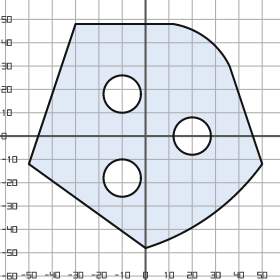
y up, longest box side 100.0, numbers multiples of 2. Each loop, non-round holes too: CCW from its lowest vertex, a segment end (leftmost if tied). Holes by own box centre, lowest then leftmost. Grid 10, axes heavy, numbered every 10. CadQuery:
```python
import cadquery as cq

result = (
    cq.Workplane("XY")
    .moveTo(0.0, -48.0)
    .threePointArc((28.0, -34.0), (50.0, -12.0))
    .lineTo(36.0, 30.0)
    .threePointArc((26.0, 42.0), (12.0, 48.0))
    .lineTo(-30.0, 48.0)
    .lineTo(-50.0, -12.0)
    .close()
    .moveTo(-10.0, -18.0)
    .circle(8.0)
    .moveTo(20.0, 0.0)
    .circle(8.0)
    .moveTo(-10.0, 18.0)
    .circle(8.0)
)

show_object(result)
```